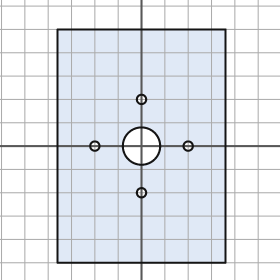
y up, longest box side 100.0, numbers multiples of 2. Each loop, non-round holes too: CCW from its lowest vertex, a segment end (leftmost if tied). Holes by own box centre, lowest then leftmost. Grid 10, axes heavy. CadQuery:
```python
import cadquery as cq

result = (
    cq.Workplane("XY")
    .moveTo(-36.0, -50.0)
    .lineTo(36.0, -50.0)
    .lineTo(36.0, 50.0)
    .lineTo(-36.0, 50.0)
    .close()
    .moveTo(0.0, -20.0)
    .circle(2.0)
    .moveTo(-20.0, 0.0)
    .circle(2.0)
    .moveTo(0.0, 0.0)
    .circle(8.0)
    .moveTo(20.0, 0.0)
    .circle(2.0)
    .moveTo(0.0, 20.0)
    .circle(2.0)
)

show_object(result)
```